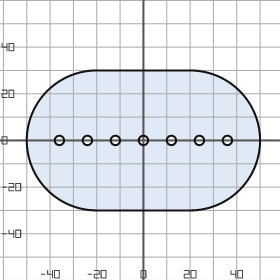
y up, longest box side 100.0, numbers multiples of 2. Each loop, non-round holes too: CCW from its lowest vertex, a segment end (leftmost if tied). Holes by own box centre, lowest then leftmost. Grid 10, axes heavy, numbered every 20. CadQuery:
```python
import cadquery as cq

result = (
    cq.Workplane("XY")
    .moveTo(-20.0, -30.0)
    .lineTo(20.0, -30.0)
    .threePointArc((50.0, 0.0), (20.0, 30.0))
    .lineTo(-20.0, 30.0)
    .threePointArc((-50.0, 0.0), (-20.0, -30.0))
    .close()
    .moveTo(-36.0, 0.0)
    .circle(2.0)
    .moveTo(-24.0, 0.0)
    .circle(2.0)
    .moveTo(-12.0, 0.0)
    .circle(2.0)
    .moveTo(0.0, 0.0)
    .circle(2.0)
    .moveTo(12.0, 0.0)
    .circle(2.0)
    .moveTo(24.0, 0.0)
    .circle(2.0)
    .moveTo(36.0, 0.0)
    .circle(2.0)
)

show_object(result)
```